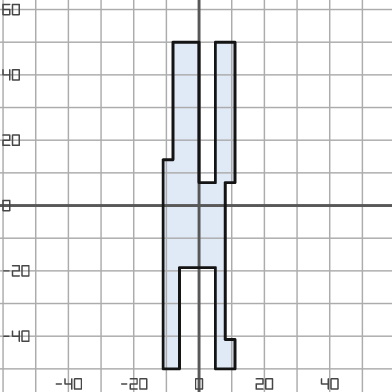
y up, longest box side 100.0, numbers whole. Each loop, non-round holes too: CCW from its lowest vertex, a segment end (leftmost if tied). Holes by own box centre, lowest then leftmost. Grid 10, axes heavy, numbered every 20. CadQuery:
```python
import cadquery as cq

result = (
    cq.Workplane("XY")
    .moveTo(-11.0, -50.0)
    .lineTo(-6.0, -50.0)
    .lineTo(-6.0, -19.0)
    .lineTo(5.0, -19.0)
    .lineTo(5.0, -50.0)
    .lineTo(11.0, -50.0)
    .lineTo(11.0, -41.0)
    .lineTo(8.0, -41.0)
    .lineTo(8.0, 7.0)
    .lineTo(11.0, 7.0)
    .lineTo(11.0, 50.0)
    .lineTo(5.0, 50.0)
    .lineTo(5.0, 7.0)
    .lineTo(0.0, 7.0)
    .lineTo(0.0, 50.0)
    .lineTo(-8.0, 50.0)
    .lineTo(-8.0, 14.0)
    .lineTo(-11.0, 14.0)
    .close()
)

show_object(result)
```